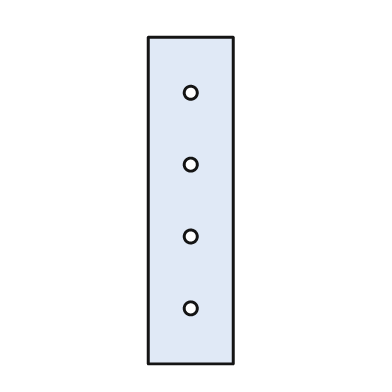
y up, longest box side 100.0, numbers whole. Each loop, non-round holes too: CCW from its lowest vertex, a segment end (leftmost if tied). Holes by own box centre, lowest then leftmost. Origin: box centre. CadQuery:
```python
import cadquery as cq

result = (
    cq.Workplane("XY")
    .moveTo(-13.0, -50.0)
    .lineTo(13.0, -50.0)
    .lineTo(13.0, 50.0)
    .lineTo(-13.0, 50.0)
    .close()
    .moveTo(0.0, -33.0)
    .circle(2.0)
    .moveTo(0.0, -11.0)
    .circle(2.0)
    .moveTo(0.0, 11.0)
    .circle(2.0)
    .moveTo(0.0, 33.0)
    .circle(2.0)
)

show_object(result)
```